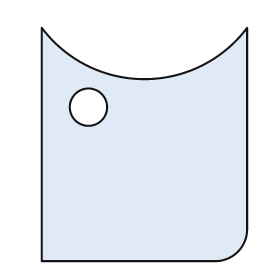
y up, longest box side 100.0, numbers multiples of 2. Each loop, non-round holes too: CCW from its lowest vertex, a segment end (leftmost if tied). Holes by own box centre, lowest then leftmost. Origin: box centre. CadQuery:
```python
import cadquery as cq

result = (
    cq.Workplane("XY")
    .moveTo(-44.0, -50.0)
    .lineTo(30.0, -50.0)
    .threePointArc((40.0, -46.0), (44.0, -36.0))
    .lineTo(44.0, 50.0)
    .threePointArc((0.0, 28.0), (-44.0, 50.0))
    .close()
    .moveTo(-24.0, 16.0)
    .circle(8.0)
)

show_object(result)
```